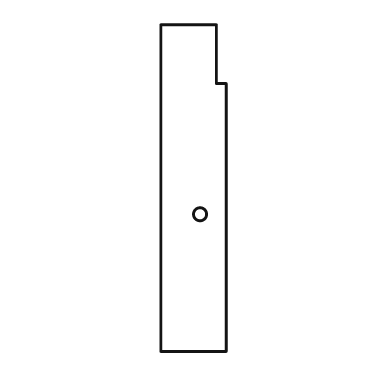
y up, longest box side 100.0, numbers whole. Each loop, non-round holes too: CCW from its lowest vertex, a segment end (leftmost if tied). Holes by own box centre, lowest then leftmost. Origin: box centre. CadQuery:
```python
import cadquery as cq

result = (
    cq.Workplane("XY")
    .moveTo(-10.0, -50.0)
    .lineTo(10.0, -50.0)
    .lineTo(10.0, 32.0)
    .lineTo(7.0, 32.0)
    .lineTo(7.0, 50.0)
    .lineTo(-10.0, 50.0)
    .close()
    .moveTo(2.0, -8.0)
    .circle(2.0)
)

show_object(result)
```